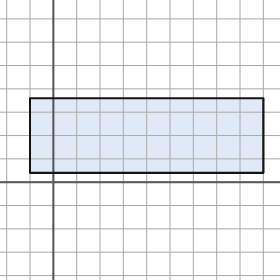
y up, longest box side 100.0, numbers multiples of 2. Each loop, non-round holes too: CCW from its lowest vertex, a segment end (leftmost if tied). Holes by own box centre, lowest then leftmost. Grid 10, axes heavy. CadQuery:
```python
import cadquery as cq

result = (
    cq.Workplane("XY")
    .moveTo(-10.0, 4.0)
    .lineTo(90.0, 4.0)
    .lineTo(90.0, 36.0)
    .lineTo(-10.0, 36.0)
    .close()
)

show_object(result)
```